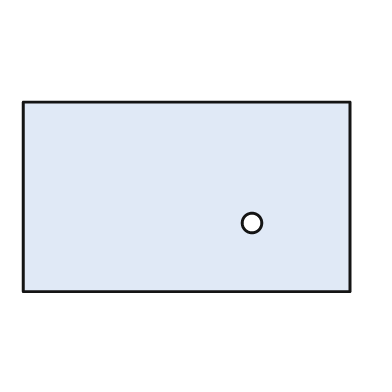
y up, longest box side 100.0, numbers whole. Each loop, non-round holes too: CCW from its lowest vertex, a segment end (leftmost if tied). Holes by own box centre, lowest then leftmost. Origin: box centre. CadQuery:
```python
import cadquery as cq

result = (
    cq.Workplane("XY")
    .moveTo(-50.0, -29.0)
    .lineTo(50.0, -29.0)
    .lineTo(50.0, 29.0)
    .lineTo(-50.0, 29.0)
    .close()
    .moveTo(20.0, -8.0)
    .circle(3.0)
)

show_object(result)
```